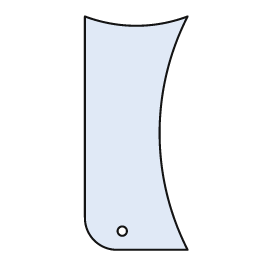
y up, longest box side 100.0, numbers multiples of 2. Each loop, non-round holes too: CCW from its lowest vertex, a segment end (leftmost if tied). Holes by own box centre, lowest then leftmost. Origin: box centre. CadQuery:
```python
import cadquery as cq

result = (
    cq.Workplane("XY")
    .moveTo(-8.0, -50.0)
    .lineTo(22.0, -50.0)
    .threePointArc((10.0, 0.0), (22.0, 50.0))
    .threePointArc((0.0, 46.0), (-22.0, 50.0))
    .lineTo(-22.0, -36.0)
    .threePointArc((-18.0, -46.0), (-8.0, -50.0))
    .close()
    .moveTo(-6.0, -42.0)
    .circle(2.0)
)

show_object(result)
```